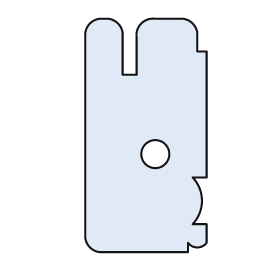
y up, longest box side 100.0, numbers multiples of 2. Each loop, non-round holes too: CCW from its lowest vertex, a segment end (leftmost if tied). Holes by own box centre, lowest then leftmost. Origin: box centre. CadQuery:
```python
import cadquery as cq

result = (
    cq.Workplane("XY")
    .moveTo(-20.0, -50.0)
    .lineTo(18.0, -50.0)
    .lineTo(18.0, -46.0)
    .threePointArc((22.0, -48.0), (26.0, -46.0))
    .lineTo(26.0, -38.0)
    .lineTo(20.0, -38.0)
    .threePointArc((24.0, -28.0), (20.0, -18.0))
    .lineTo(26.0, -18.0)
    .lineTo(26.0, 36.0)
    .lineTo(22.0, 36.0)
    .lineTo(22.0, 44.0)
    .threePointArc((20.0, 48.0), (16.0, 50.0))
    .lineTo(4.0, 50.0)
    .threePointArc((-2.0, 48.0), (-4.0, 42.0))
    .lineTo(-4.0, 26.0)
    .lineTo(-10.0, 26.0)
    .lineTo(-10.0, 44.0)
    .threePointArc((-12.0, 48.0), (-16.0, 50.0))
    .lineTo(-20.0, 50.0)
    .threePointArc((-24.0, 48.0), (-26.0, 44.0))
    .lineTo(-26.0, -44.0)
    .threePointArc((-24.0, -48.0), (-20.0, -50.0))
    .close()
    .moveTo(4.0, -8.0)
    .circle(6.0)
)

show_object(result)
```